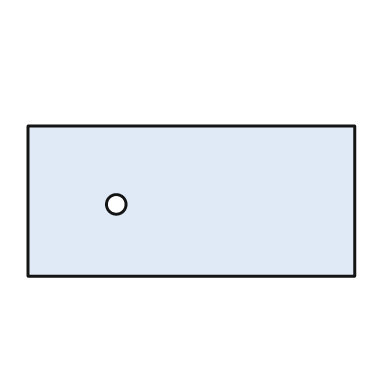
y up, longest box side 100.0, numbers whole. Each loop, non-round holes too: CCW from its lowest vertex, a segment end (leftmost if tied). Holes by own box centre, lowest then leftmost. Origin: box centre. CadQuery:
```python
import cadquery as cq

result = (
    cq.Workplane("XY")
    .moveTo(-50.0, -23.0)
    .lineTo(50.0, -23.0)
    .lineTo(50.0, 23.0)
    .lineTo(-50.0, 23.0)
    .close()
    .moveTo(-23.0, -1.0)
    .circle(3.0)
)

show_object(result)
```